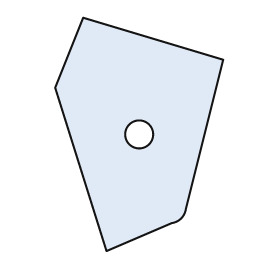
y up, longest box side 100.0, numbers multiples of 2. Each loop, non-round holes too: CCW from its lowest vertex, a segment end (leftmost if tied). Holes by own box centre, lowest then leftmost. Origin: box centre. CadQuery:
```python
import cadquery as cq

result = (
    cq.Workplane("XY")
    .moveTo(-14.0, -50.0)
    .lineTo(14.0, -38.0)
    .threePointArc((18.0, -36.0), (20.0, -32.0))
    .lineTo(36.0, 32.0)
    .lineTo(-24.0, 50.0)
    .lineTo(-36.0, 20.0)
    .close()
    .moveTo(0.0, 0.0)
    .circle(6.0)
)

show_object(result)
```